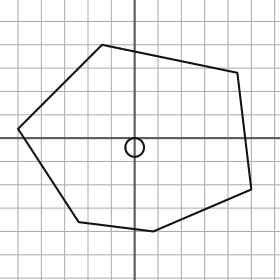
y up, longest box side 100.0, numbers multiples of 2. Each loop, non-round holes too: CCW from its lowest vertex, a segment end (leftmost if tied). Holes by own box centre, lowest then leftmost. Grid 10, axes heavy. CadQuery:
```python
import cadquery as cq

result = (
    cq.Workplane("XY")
    .moveTo(8.0, -40.0)
    .lineTo(50.0, -22.0)
    .lineTo(44.0, 28.0)
    .lineTo(-14.0, 40.0)
    .lineTo(-50.0, 4.0)
    .lineTo(-24.0, -36.0)
    .close()
    .moveTo(0.0, -4.0)
    .circle(4.0)
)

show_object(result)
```